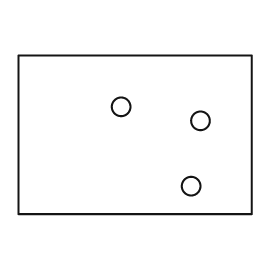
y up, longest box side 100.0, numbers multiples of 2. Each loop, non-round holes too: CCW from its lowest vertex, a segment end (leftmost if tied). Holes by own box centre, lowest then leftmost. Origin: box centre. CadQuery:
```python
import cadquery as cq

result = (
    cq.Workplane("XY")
    .moveTo(-50.0, -34.0)
    .lineTo(50.0, -34.0)
    .lineTo(50.0, 34.0)
    .lineTo(-50.0, 34.0)
    .close()
    .moveTo(24.0, -22.0)
    .circle(4.0)
    .moveTo(28.0, 6.0)
    .circle(4.0)
    .moveTo(-6.0, 12.0)
    .circle(4.0)
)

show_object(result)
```